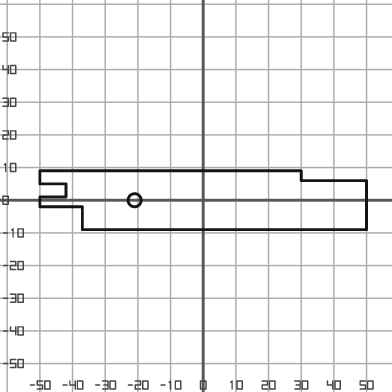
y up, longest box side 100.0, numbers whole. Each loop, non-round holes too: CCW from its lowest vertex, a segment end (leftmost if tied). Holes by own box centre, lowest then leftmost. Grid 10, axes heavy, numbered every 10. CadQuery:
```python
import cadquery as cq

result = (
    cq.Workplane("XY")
    .moveTo(-37.0, -9.0)
    .lineTo(50.0, -9.0)
    .lineTo(50.0, 6.0)
    .lineTo(30.0, 6.0)
    .lineTo(30.0, 9.0)
    .lineTo(-50.0, 9.0)
    .lineTo(-50.0, 5.0)
    .lineTo(-42.0, 5.0)
    .lineTo(-42.0, 1.0)
    .lineTo(-50.0, 1.0)
    .lineTo(-50.0, -2.0)
    .lineTo(-37.0, -2.0)
    .close()
    .moveTo(-21.0, 0.0)
    .circle(2.0)
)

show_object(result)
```